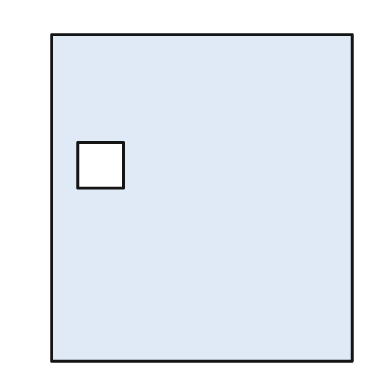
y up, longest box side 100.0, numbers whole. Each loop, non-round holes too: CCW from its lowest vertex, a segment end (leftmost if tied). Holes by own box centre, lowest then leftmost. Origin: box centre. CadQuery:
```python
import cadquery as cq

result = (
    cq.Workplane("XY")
    .moveTo(-46.0, -50.0)
    .lineTo(46.0, -50.0)
    .lineTo(46.0, 50.0)
    .lineTo(-46.0, 50.0)
    .close()
    .moveTo(-38.0, 3.0)
    .lineTo(-24.0, 3.0)
    .lineTo(-24.0, 17.0)
    .lineTo(-38.0, 17.0)
    .close()
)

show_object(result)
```